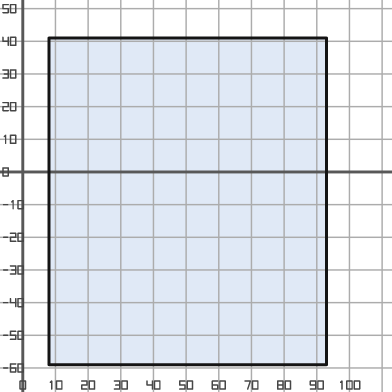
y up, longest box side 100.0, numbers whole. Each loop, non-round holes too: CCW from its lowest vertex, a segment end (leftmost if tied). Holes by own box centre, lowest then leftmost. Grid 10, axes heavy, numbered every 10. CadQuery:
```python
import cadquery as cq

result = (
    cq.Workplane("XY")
    .moveTo(8.0, -59.0)
    .lineTo(93.0, -59.0)
    .lineTo(93.0, 41.0)
    .lineTo(8.0, 41.0)
    .close()
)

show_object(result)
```